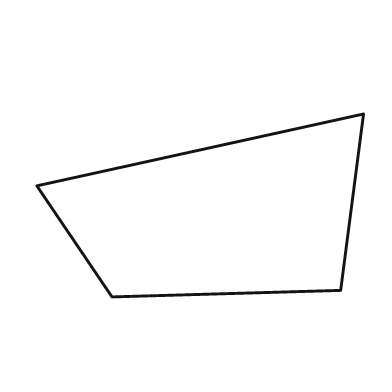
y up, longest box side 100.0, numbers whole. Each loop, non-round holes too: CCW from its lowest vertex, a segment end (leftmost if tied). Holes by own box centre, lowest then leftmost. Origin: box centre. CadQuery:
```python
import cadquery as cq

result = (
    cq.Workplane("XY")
    .moveTo(-27.0, -28.0)
    .lineTo(43.0, -26.0)
    .lineTo(50.0, 28.0)
    .lineTo(-50.0, 6.0)
    .close()
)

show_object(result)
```